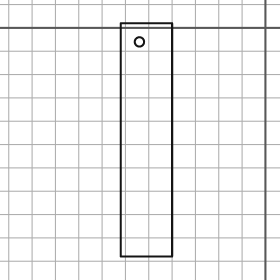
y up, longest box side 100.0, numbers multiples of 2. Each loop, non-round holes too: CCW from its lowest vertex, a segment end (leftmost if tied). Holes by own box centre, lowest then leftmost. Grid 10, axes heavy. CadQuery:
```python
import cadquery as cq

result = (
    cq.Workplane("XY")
    .moveTo(-62.0, -98.0)
    .lineTo(-40.0, -98.0)
    .lineTo(-40.0, 2.0)
    .lineTo(-62.0, 2.0)
    .close()
    .moveTo(-54.0, -6.0)
    .circle(2.0)
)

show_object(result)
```